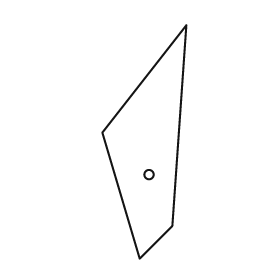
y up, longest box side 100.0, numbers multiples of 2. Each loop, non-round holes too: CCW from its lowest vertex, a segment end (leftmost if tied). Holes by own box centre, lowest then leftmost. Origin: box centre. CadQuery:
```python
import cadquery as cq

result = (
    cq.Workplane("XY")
    .moveTo(-2.0, -50.0)
    .lineTo(12.0, -36.0)
    .lineTo(18.0, 50.0)
    .lineTo(-18.0, 4.0)
    .close()
    .moveTo(2.0, -14.0)
    .circle(2.0)
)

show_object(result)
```